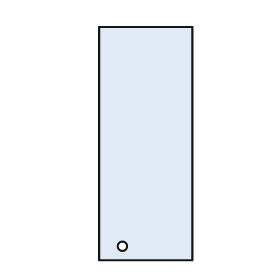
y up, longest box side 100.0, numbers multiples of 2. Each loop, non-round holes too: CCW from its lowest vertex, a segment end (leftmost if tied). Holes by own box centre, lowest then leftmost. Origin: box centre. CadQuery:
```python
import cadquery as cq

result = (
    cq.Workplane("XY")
    .moveTo(-20.0, -50.0)
    .lineTo(20.0, -50.0)
    .lineTo(20.0, 50.0)
    .lineTo(-20.0, 50.0)
    .close()
    .moveTo(-10.0, -44.0)
    .circle(2.0)
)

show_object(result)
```